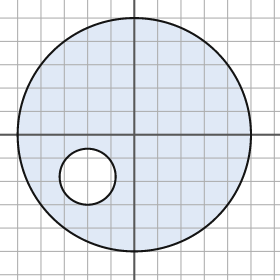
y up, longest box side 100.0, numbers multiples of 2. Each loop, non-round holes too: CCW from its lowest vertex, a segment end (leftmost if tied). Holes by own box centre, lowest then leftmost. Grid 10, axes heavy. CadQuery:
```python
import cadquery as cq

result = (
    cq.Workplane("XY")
    .moveTo(0.0, 0.0)
    .circle(50.0)
    .moveTo(-20.0, -18.0)
    .circle(12.0)
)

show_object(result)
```